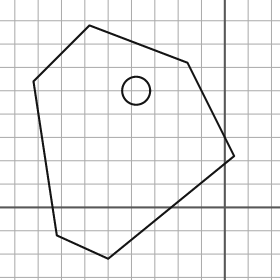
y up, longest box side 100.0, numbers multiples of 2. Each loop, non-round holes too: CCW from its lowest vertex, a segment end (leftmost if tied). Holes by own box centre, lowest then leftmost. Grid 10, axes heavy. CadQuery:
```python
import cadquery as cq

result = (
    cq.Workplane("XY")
    .moveTo(-50.0, -22.0)
    .lineTo(4.0, 22.0)
    .lineTo(-16.0, 62.0)
    .lineTo(-58.0, 78.0)
    .lineTo(-82.0, 54.0)
    .lineTo(-72.0, -12.0)
    .close()
    .moveTo(-38.0, 50.0)
    .circle(6.0)
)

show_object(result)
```